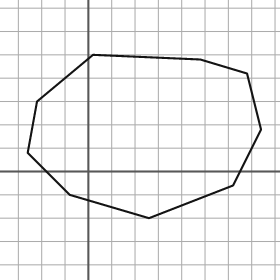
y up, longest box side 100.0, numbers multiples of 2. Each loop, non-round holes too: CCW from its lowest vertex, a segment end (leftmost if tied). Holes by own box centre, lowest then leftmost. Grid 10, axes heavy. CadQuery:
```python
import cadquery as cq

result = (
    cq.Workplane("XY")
    .moveTo(26.0, -20.0)
    .lineTo(62.0, -6.0)
    .lineTo(74.0, 18.0)
    .lineTo(68.0, 42.0)
    .lineTo(48.0, 48.0)
    .lineTo(2.0, 50.0)
    .lineTo(-22.0, 30.0)
    .lineTo(-26.0, 8.0)
    .lineTo(-8.0, -10.0)
    .close()
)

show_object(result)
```